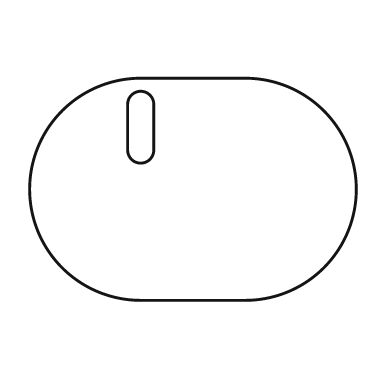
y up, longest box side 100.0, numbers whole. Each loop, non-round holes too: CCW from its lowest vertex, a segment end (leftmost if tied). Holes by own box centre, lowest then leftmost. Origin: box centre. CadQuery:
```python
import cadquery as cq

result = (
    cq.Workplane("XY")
    .moveTo(-16.0, -34.0)
    .lineTo(16.0, -34.0)
    .threePointArc((50.0, 0.0), (16.0, 34.0))
    .lineTo(-16.0, 34.0)
    .threePointArc((-50.0, 0.0), (-16.0, -34.0))
    .close()
    .moveTo(-20.0, 12.0)
    .threePointArc((-16.0, 8.0), (-12.0, 12.0))
    .lineTo(-12.0, 26.0)
    .threePointArc((-16.0, 30.0), (-20.0, 26.0))
    .close()
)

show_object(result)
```